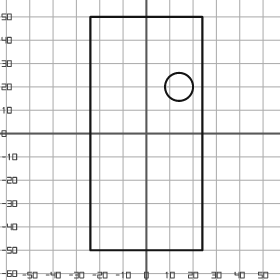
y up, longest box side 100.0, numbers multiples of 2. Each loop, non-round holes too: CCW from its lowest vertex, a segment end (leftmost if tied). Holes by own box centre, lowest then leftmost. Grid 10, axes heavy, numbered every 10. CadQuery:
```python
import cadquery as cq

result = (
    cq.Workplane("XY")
    .moveTo(-24.0, -50.0)
    .lineTo(24.0, -50.0)
    .lineTo(24.0, 50.0)
    .lineTo(-24.0, 50.0)
    .close()
    .moveTo(14.0, 20.0)
    .circle(6.0)
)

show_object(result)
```